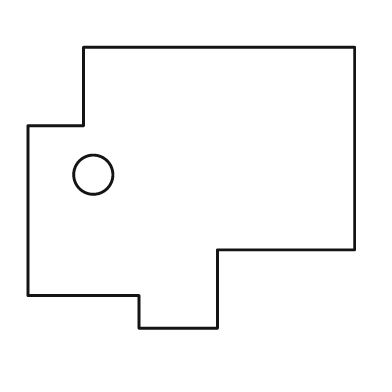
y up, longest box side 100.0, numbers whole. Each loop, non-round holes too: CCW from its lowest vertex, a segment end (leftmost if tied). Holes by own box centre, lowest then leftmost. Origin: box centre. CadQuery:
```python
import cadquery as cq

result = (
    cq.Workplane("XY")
    .moveTo(-16.0, -43.0)
    .lineTo(8.0, -43.0)
    .lineTo(8.0, -19.0)
    .lineTo(50.0, -19.0)
    .lineTo(50.0, 43.0)
    .lineTo(-33.0, 43.0)
    .lineTo(-33.0, 19.0)
    .lineTo(-50.0, 19.0)
    .lineTo(-50.0, -33.0)
    .lineTo(-16.0, -33.0)
    .close()
    .moveTo(-30.0, 4.0)
    .circle(6.0)
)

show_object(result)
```